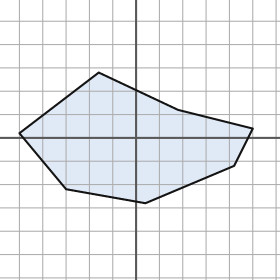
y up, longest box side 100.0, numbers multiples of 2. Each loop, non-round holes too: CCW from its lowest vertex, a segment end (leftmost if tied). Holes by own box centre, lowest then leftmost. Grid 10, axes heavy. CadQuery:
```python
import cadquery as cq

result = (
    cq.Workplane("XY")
    .moveTo(4.0, -28.0)
    .lineTo(42.0, -12.0)
    .lineTo(50.0, 4.0)
    .lineTo(18.0, 12.0)
    .lineTo(-16.0, 28.0)
    .lineTo(-50.0, 2.0)
    .lineTo(-30.0, -22.0)
    .close()
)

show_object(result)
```